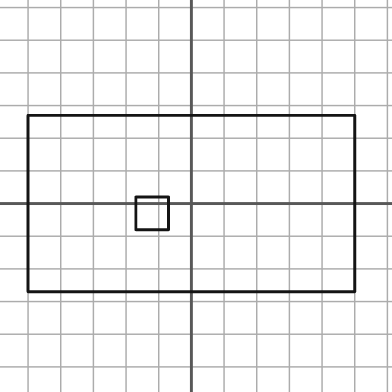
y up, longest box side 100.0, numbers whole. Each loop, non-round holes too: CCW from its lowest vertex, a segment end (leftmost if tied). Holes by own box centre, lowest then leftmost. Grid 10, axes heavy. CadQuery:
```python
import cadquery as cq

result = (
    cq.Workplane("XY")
    .moveTo(-50.0, -27.0)
    .lineTo(50.0, -27.0)
    .lineTo(50.0, 27.0)
    .lineTo(-50.0, 27.0)
    .close()
    .moveTo(-17.0, -8.0)
    .lineTo(-7.0, -8.0)
    .lineTo(-7.0, 2.0)
    .lineTo(-17.0, 2.0)
    .close()
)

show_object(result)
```